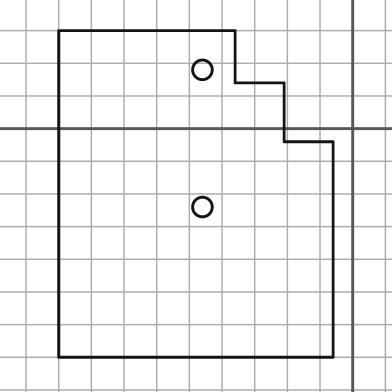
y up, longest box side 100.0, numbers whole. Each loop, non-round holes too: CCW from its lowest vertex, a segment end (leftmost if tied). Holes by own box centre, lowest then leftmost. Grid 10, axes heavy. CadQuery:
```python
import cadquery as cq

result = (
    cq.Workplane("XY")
    .moveTo(-90.0, -70.0)
    .lineTo(-6.0, -70.0)
    .lineTo(-6.0, -4.0)
    .lineTo(-21.0, -4.0)
    .lineTo(-21.0, 14.0)
    .lineTo(-36.0, 14.0)
    .lineTo(-36.0, 30.0)
    .lineTo(-90.0, 30.0)
    .close()
    .moveTo(-46.0, -24.0)
    .circle(3.0)
    .moveTo(-46.0, 18.0)
    .circle(3.0)
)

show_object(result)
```